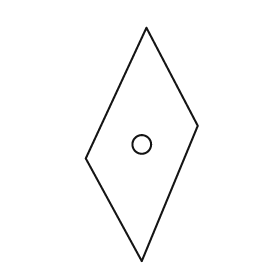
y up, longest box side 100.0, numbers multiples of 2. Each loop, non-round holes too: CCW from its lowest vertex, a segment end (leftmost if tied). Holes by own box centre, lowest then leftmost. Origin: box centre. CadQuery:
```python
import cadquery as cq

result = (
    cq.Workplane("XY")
    .moveTo(0.0, -50.0)
    .lineTo(24.0, 8.0)
    .lineTo(2.0, 50.0)
    .lineTo(-24.0, -6.0)
    .close()
    .moveTo(0.0, 0.0)
    .circle(4.0)
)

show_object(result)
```